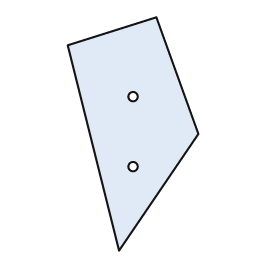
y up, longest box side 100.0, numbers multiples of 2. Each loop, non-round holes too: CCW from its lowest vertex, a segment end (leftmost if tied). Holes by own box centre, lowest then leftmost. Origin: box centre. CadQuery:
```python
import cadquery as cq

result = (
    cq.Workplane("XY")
    .moveTo(-6.0, -50.0)
    .lineTo(28.0, 0.0)
    .lineTo(10.0, 50.0)
    .lineTo(-28.0, 38.0)
    .close()
    .moveTo(0.0, -14.0)
    .circle(2.0)
    .moveTo(0.0, 16.0)
    .circle(2.0)
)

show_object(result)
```